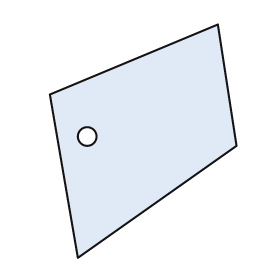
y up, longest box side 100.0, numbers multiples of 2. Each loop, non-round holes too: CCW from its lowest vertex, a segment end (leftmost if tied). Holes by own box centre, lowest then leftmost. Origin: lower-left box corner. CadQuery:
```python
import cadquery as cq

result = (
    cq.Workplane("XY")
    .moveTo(12.0, 0.0)
    .lineTo(80.0, 48.0)
    .lineTo(72.0, 100.0)
    .lineTo(0.0, 70.0)
    .close()
    .moveTo(16.0, 52.0)
    .circle(4.0)
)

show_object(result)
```